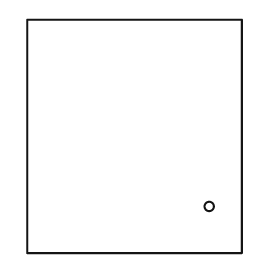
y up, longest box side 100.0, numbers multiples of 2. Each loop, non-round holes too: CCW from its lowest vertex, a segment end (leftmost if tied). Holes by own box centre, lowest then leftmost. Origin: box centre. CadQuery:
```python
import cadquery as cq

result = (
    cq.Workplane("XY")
    .moveTo(-46.0, -50.0)
    .lineTo(46.0, -50.0)
    .lineTo(46.0, 50.0)
    .lineTo(-46.0, 50.0)
    .close()
    .moveTo(32.0, -30.0)
    .circle(2.0)
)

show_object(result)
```